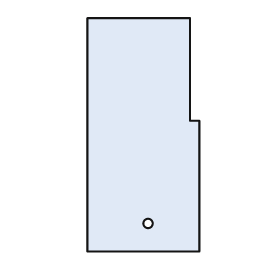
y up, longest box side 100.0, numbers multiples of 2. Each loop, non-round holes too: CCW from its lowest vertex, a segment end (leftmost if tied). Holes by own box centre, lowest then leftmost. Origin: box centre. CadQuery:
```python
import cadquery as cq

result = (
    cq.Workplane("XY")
    .moveTo(-24.0, -50.0)
    .lineTo(24.0, -50.0)
    .lineTo(24.0, 6.0)
    .lineTo(20.0, 6.0)
    .lineTo(20.0, 50.0)
    .lineTo(-24.0, 50.0)
    .close()
    .moveTo(2.0, -38.0)
    .circle(2.0)
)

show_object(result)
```